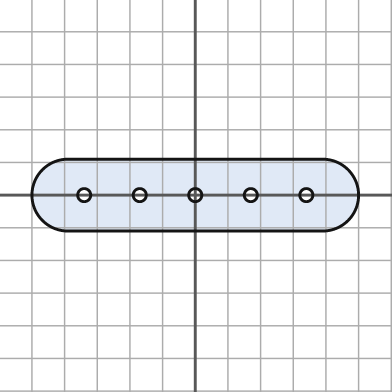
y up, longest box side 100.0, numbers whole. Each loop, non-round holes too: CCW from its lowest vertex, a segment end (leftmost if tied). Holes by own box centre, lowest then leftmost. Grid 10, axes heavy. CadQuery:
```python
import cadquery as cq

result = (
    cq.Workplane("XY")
    .moveTo(-39.0, -11.0)
    .lineTo(39.0, -11.0)
    .threePointArc((50.0, 0.0), (39.0, 11.0))
    .lineTo(-39.0, 11.0)
    .threePointArc((-50.0, 0.0), (-39.0, -11.0))
    .close()
    .moveTo(-34.0, 0.0)
    .circle(2.0)
    .moveTo(-17.0, 0.0)
    .circle(2.0)
    .moveTo(0.0, 0.0)
    .circle(2.0)
    .moveTo(17.0, 0.0)
    .circle(2.0)
    .moveTo(34.0, 0.0)
    .circle(2.0)
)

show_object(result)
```